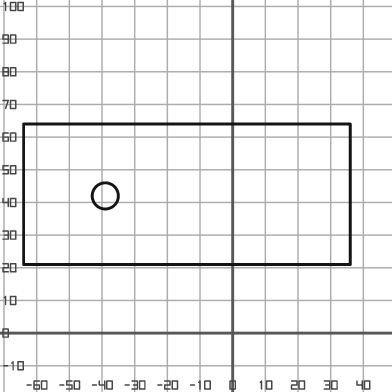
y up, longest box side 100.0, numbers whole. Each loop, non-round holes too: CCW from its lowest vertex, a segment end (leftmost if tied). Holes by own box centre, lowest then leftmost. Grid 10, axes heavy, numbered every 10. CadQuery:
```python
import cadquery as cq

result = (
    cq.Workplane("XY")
    .moveTo(-64.0, 21.0)
    .lineTo(36.0, 21.0)
    .lineTo(36.0, 64.0)
    .lineTo(-64.0, 64.0)
    .close()
    .moveTo(-39.0, 42.0)
    .circle(4.0)
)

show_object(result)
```